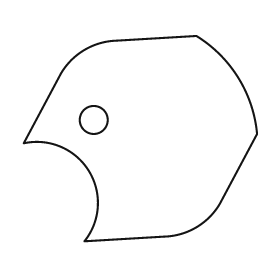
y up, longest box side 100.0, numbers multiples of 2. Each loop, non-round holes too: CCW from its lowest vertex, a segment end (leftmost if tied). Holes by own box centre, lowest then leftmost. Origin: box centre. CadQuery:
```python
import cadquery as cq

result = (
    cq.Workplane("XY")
    .moveTo(-24.0, -44.0)
    .lineTo(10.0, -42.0)
    .threePointArc((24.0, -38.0), (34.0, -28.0))
    .lineTo(50.0, 2.0)
    .threePointArc((42.0, 26.0), (24.0, 44.0))
    .lineTo(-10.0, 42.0)
    .threePointArc((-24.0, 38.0), (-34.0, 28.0))
    .lineTo(-50.0, -2.0)
    .threePointArc((-22.0, -14.0), (-24.0, -44.0))
    .close()
    .moveTo(-20.0, 8.0)
    .circle(6.0)
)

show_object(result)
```